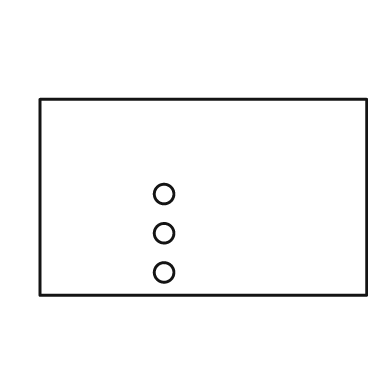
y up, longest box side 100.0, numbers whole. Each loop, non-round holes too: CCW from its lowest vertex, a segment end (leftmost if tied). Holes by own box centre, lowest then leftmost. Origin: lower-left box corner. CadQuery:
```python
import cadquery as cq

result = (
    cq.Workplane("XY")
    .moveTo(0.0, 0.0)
    .lineTo(100.0, 0.0)
    .lineTo(100.0, 60.0)
    .lineTo(0.0, 60.0)
    .close()
    .moveTo(38.0, 7.0)
    .circle(3.0)
    .moveTo(38.0, 19.0)
    .circle(3.0)
    .moveTo(38.0, 31.0)
    .circle(3.0)
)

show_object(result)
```